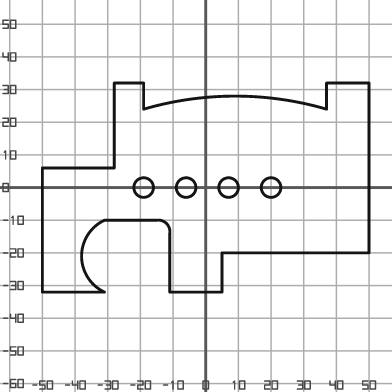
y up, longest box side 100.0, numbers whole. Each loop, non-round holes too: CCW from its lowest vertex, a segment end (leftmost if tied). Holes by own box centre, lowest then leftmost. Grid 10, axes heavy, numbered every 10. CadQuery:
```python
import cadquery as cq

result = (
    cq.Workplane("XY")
    .moveTo(-50.0, -32.0)
    .lineTo(-31.0, -32.0)
    .threePointArc((-38.0, -21.0), (-31.0, -10.0))
    .lineTo(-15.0, -10.0)
    .threePointArc((-12.0, -11.0), (-11.0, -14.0))
    .lineTo(-11.0, -32.0)
    .lineTo(5.0, -32.0)
    .lineTo(5.0, -20.0)
    .lineTo(50.0, -20.0)
    .lineTo(50.0, 32.0)
    .lineTo(37.0, 32.0)
    .lineTo(37.0, 24.0)
    .threePointArc((9.0, 28.0), (-19.0, 24.0))
    .lineTo(-19.0, 32.0)
    .lineTo(-28.0, 32.0)
    .lineTo(-28.0, 6.0)
    .lineTo(-50.0, 6.0)
    .close()
    .moveTo(-19.0, 0.0)
    .circle(3.0)
    .moveTo(-6.0, 0.0)
    .circle(3.0)
    .moveTo(7.0, 0.0)
    .circle(3.0)
    .moveTo(20.0, 0.0)
    .circle(3.0)
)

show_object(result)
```